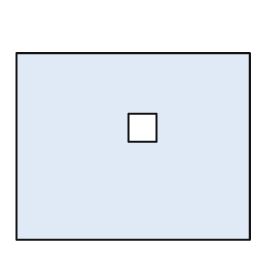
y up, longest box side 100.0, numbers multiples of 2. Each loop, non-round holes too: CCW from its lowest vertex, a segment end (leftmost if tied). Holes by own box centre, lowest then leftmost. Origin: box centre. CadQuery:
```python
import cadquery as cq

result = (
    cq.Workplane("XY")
    .moveTo(-50.0, -40.0)
    .lineTo(50.0, -40.0)
    .lineTo(50.0, 40.0)
    .lineTo(-50.0, 40.0)
    .close()
    .moveTo(-2.0, 2.0)
    .lineTo(10.0, 2.0)
    .lineTo(10.0, 14.0)
    .lineTo(-2.0, 14.0)
    .close()
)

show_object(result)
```